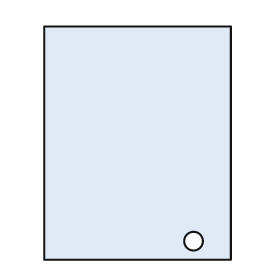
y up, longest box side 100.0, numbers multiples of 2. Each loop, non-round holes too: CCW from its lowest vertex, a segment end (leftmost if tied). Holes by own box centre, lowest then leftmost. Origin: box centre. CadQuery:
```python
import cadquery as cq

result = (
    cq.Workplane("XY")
    .moveTo(-40.0, -50.0)
    .lineTo(40.0, -50.0)
    .lineTo(40.0, 50.0)
    .lineTo(-40.0, 50.0)
    .close()
    .moveTo(24.0, -42.0)
    .circle(4.0)
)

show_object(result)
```